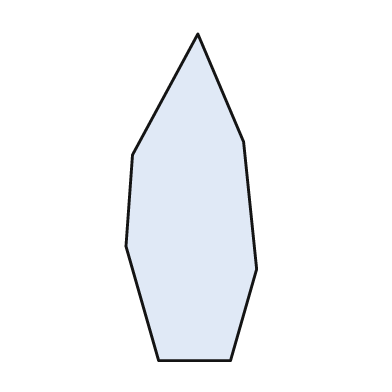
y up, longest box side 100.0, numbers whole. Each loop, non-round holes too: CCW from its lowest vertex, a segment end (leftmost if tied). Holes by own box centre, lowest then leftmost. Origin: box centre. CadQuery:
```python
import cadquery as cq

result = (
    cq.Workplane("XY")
    .moveTo(-10.0, -50.0)
    .lineTo(12.0, -50.0)
    .lineTo(20.0, -22.0)
    .lineTo(16.0, 17.0)
    .lineTo(2.0, 50.0)
    .lineTo(-18.0, 13.0)
    .lineTo(-20.0, -15.0)
    .close()
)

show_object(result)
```